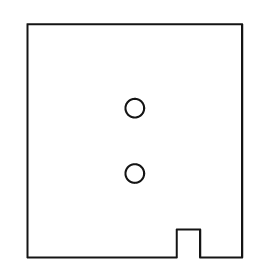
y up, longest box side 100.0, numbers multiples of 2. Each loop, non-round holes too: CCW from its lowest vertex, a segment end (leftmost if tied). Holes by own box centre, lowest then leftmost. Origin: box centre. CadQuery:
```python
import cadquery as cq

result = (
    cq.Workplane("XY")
    .moveTo(-46.0, -50.0)
    .lineTo(18.0, -50.0)
    .lineTo(18.0, -38.0)
    .lineTo(28.0, -38.0)
    .lineTo(28.0, -50.0)
    .lineTo(46.0, -50.0)
    .lineTo(46.0, 50.0)
    .lineTo(-46.0, 50.0)
    .close()
    .moveTo(0.0, -14.0)
    .circle(4.0)
    .moveTo(0.0, 14.0)
    .circle(4.0)
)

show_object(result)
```